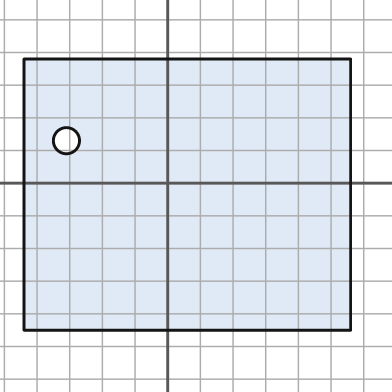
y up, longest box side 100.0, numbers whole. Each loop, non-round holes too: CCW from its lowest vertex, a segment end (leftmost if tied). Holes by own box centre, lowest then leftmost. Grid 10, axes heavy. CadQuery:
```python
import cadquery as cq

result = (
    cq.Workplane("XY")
    .moveTo(-44.0, -45.0)
    .lineTo(56.0, -45.0)
    .lineTo(56.0, 38.0)
    .lineTo(-44.0, 38.0)
    .close()
    .moveTo(-31.0, 13.0)
    .circle(4.0)
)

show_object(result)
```